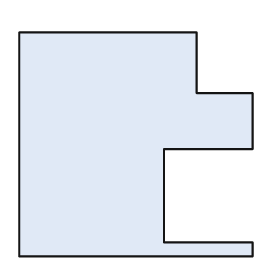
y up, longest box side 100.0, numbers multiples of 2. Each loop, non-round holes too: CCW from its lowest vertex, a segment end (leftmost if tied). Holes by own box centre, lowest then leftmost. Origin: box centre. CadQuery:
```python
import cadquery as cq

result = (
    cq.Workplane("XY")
    .moveTo(-50.0, -48.0)
    .lineTo(50.0, -48.0)
    .lineTo(50.0, -42.0)
    .lineTo(12.0, -42.0)
    .lineTo(12.0, -2.0)
    .lineTo(50.0, -2.0)
    .lineTo(50.0, 22.0)
    .lineTo(26.0, 22.0)
    .lineTo(26.0, 48.0)
    .lineTo(-50.0, 48.0)
    .close()
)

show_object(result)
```